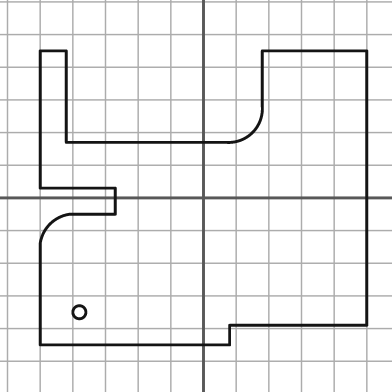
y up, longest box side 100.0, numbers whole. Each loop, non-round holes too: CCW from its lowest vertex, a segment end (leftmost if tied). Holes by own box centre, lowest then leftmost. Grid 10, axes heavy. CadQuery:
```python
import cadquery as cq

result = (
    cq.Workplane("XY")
    .moveTo(-50.0, -45.0)
    .lineTo(8.0, -45.0)
    .lineTo(8.0, -39.0)
    .lineTo(50.0, -39.0)
    .lineTo(50.0, 45.0)
    .lineTo(18.0, 45.0)
    .lineTo(18.0, 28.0)
    .threePointArc((15.0, 20.0), (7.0, 17.0))
    .lineTo(-42.0, 17.0)
    .lineTo(-42.0, 45.0)
    .lineTo(-50.0, 45.0)
    .lineTo(-50.0, 3.0)
    .lineTo(-27.0, 3.0)
    .lineTo(-27.0, -5.0)
    .lineTo(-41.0, -5.0)
    .threePointArc((-47.0, -8.0), (-50.0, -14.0))
    .close()
    .moveTo(-38.0, -35.0)
    .circle(2.0)
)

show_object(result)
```